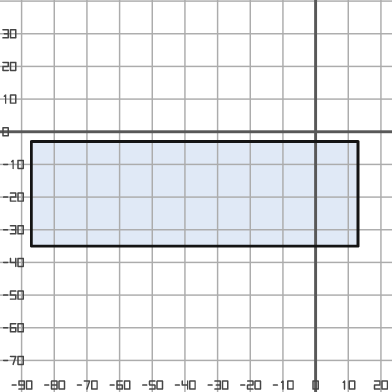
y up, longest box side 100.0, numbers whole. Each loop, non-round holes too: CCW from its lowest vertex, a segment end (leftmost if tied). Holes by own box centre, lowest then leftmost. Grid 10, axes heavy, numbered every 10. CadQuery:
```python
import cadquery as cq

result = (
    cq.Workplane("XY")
    .moveTo(-87.0, -35.0)
    .lineTo(13.0, -35.0)
    .lineTo(13.0, -3.0)
    .lineTo(-87.0, -3.0)
    .close()
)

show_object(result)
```